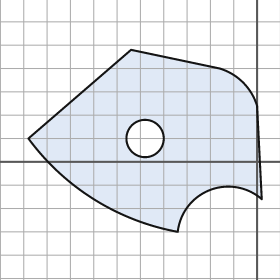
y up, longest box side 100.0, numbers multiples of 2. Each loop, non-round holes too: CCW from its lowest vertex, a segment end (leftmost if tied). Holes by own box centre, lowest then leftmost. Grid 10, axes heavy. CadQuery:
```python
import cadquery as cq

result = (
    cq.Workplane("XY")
    .moveTo(-34.0, -30.0)
    .threePointArc((-20.0, -12.0), (2.0, -16.0))
    .lineTo(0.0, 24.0)
    .threePointArc((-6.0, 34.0), (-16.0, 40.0))
    .lineTo(-54.0, 48.0)
    .lineTo(-98.0, 10.0)
    .threePointArc((-70.0, -16.0), (-34.0, -30.0))
    .close()
    .moveTo(-48.0, 10.0)
    .circle(8.0)
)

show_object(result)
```